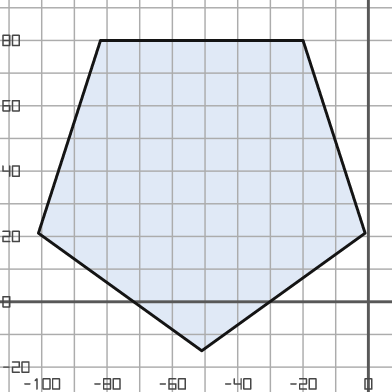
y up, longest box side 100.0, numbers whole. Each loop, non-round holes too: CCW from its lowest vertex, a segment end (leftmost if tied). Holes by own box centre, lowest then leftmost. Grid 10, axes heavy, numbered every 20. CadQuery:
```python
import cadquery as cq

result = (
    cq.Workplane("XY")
    .moveTo(-51.0, -15.0)
    .lineTo(-1.0, 21.0)
    .lineTo(-20.0, 80.0)
    .lineTo(-82.0, 80.0)
    .lineTo(-101.0, 21.0)
    .close()
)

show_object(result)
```